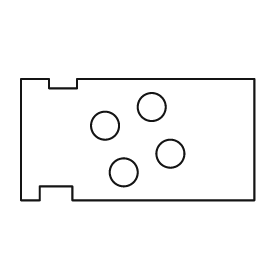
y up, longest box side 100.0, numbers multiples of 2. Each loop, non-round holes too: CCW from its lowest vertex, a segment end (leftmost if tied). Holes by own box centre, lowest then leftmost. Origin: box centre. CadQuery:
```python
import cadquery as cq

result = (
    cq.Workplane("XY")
    .moveTo(-50.0, -26.0)
    .lineTo(-42.0, -26.0)
    .lineTo(-42.0, -20.0)
    .lineTo(-28.0, -20.0)
    .lineTo(-28.0, -26.0)
    .lineTo(50.0, -26.0)
    .lineTo(50.0, 26.0)
    .lineTo(-26.0, 26.0)
    .lineTo(-26.0, 22.0)
    .lineTo(-38.0, 22.0)
    .lineTo(-38.0, 26.0)
    .lineTo(-50.0, 26.0)
    .close()
    .moveTo(-6.0, -14.0)
    .circle(6.0)
    .moveTo(14.0, -6.0)
    .circle(6.0)
    .moveTo(-14.0, 6.0)
    .circle(6.0)
    .moveTo(6.0, 14.0)
    .circle(6.0)
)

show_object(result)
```